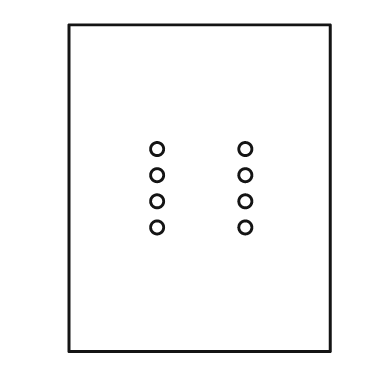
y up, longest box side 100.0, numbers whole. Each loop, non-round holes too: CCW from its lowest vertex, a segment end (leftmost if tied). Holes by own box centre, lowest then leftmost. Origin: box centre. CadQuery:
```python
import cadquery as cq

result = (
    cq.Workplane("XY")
    .moveTo(-40.0, -50.0)
    .lineTo(40.0, -50.0)
    .lineTo(40.0, 50.0)
    .lineTo(-40.0, 50.0)
    .close()
    .moveTo(-13.0, -12.0)
    .circle(2.0)
    .moveTo(14.0, -12.0)
    .circle(2.0)
    .moveTo(-13.0, -4.0)
    .circle(2.0)
    .moveTo(14.0, -4.0)
    .circle(2.0)
    .moveTo(-13.0, 4.0)
    .circle(2.0)
    .moveTo(14.0, 4.0)
    .circle(2.0)
    .moveTo(-13.0, 12.0)
    .circle(2.0)
    .moveTo(14.0, 12.0)
    .circle(2.0)
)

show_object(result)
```